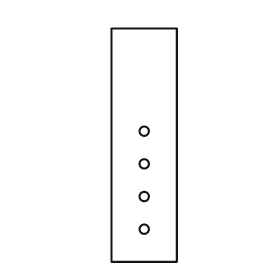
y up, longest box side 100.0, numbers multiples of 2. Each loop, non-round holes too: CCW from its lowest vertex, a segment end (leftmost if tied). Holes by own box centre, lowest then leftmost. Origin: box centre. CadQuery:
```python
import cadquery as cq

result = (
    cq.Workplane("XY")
    .moveTo(-14.0, -50.0)
    .lineTo(14.0, -50.0)
    .lineTo(14.0, 50.0)
    .lineTo(-14.0, 50.0)
    .close()
    .moveTo(0.0, -36.0)
    .circle(2.0)
    .moveTo(0.0, -22.0)
    .circle(2.0)
    .moveTo(0.0, -8.0)
    .circle(2.0)
    .moveTo(0.0, 6.0)
    .circle(2.0)
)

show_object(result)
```